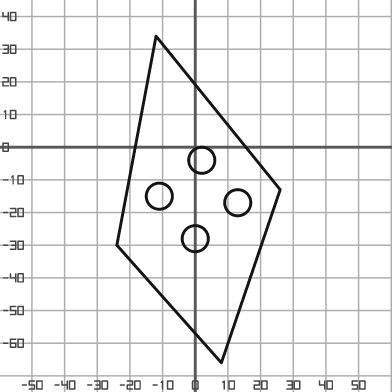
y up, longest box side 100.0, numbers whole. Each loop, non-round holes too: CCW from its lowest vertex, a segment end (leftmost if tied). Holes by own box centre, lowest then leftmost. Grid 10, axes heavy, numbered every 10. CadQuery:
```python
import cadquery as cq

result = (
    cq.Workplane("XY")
    .moveTo(8.0, -66.0)
    .lineTo(26.0, -13.0)
    .lineTo(-12.0, 34.0)
    .lineTo(-24.0, -30.0)
    .close()
    .moveTo(0.0, -28.0)
    .circle(4.0)
    .moveTo(13.0, -17.0)
    .circle(4.0)
    .moveTo(-11.0, -15.0)
    .circle(4.0)
    .moveTo(2.0, -4.0)
    .circle(4.0)
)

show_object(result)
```